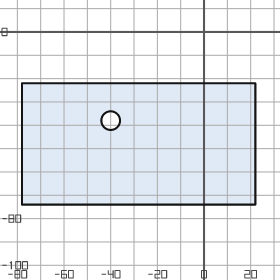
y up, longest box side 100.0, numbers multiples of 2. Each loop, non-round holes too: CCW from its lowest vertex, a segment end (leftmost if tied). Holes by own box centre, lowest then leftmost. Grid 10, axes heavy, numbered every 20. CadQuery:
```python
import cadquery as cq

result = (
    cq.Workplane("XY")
    .moveTo(-78.0, -74.0)
    .lineTo(22.0, -74.0)
    .lineTo(22.0, -22.0)
    .lineTo(-78.0, -22.0)
    .close()
    .moveTo(-40.0, -38.0)
    .circle(4.0)
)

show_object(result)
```